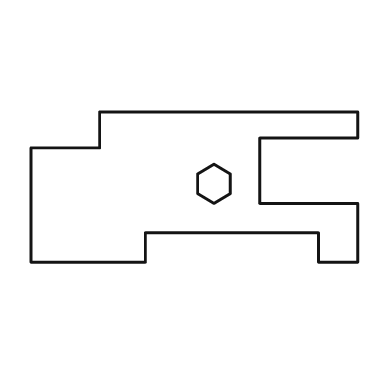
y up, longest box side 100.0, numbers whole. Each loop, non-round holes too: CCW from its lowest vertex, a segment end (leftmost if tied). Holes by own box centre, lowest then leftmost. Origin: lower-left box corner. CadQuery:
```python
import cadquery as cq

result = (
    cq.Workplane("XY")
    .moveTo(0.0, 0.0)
    .lineTo(35.0, 0.0)
    .lineTo(35.0, 9.0)
    .lineTo(88.0, 9.0)
    .lineTo(88.0, 0.0)
    .lineTo(100.0, 0.0)
    .lineTo(100.0, 18.0)
    .lineTo(70.0, 18.0)
    .lineTo(70.0, 38.0)
    .lineTo(100.0, 38.0)
    .lineTo(100.0, 46.0)
    .lineTo(21.0, 46.0)
    .lineTo(21.0, 35.0)
    .lineTo(0.0, 35.0)
    .close()
    .moveTo(56.0, 18.0)
    .lineTo(61.0, 21.0)
    .lineTo(61.0, 27.0)
    .lineTo(56.0, 30.0)
    .lineTo(51.0, 27.0)
    .lineTo(51.0, 21.0)
    .close()
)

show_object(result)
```